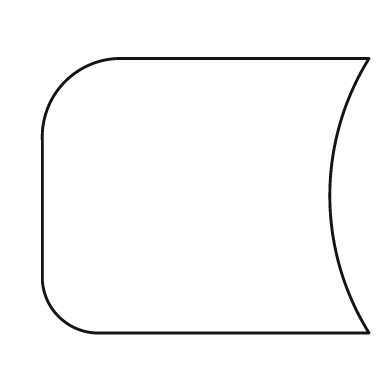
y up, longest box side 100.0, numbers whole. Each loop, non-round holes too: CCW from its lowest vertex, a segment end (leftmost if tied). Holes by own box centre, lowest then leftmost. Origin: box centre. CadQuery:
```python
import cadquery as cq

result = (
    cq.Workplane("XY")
    .moveTo(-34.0, -42.0)
    .lineTo(50.0, -42.0)
    .threePointArc((38.0, 0.0), (50.0, 42.0))
    .lineTo(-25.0, 42.0)
    .threePointArc((-43.0, 35.0), (-50.0, 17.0))
    .lineTo(-50.0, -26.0)
    .threePointArc((-45.0, -37.0), (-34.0, -42.0))
    .close()
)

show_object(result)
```